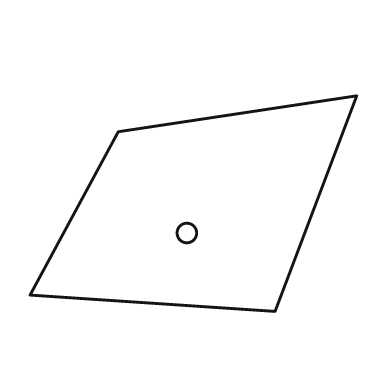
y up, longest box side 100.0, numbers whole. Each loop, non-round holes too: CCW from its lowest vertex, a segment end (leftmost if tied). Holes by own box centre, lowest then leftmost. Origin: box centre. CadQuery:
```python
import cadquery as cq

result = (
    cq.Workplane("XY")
    .moveTo(25.0, -33.0)
    .lineTo(50.0, 33.0)
    .lineTo(-23.0, 22.0)
    .lineTo(-50.0, -28.0)
    .close()
    .moveTo(-2.0, -9.0)
    .circle(3.0)
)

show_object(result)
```